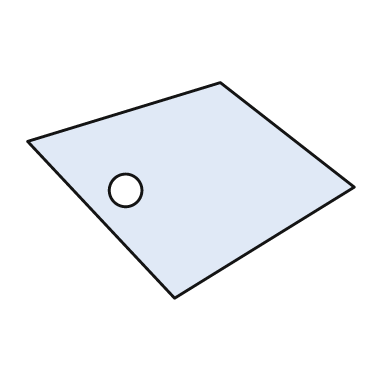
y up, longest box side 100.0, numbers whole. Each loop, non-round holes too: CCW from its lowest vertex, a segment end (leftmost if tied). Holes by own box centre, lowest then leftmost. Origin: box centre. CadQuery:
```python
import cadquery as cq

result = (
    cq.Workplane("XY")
    .moveTo(-5.0, -33.0)
    .lineTo(50.0, 1.0)
    .lineTo(9.0, 33.0)
    .lineTo(-50.0, 15.0)
    .close()
    .moveTo(-20.0, 0.0)
    .circle(5.0)
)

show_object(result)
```